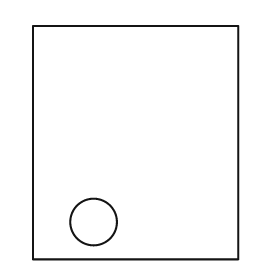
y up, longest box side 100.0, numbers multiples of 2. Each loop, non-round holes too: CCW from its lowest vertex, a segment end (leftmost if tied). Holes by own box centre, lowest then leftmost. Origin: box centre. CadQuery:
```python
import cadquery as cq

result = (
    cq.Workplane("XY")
    .moveTo(-44.0, -50.0)
    .lineTo(44.0, -50.0)
    .lineTo(44.0, 50.0)
    .lineTo(-44.0, 50.0)
    .close()
    .moveTo(-18.0, -34.0)
    .circle(10.0)
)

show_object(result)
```